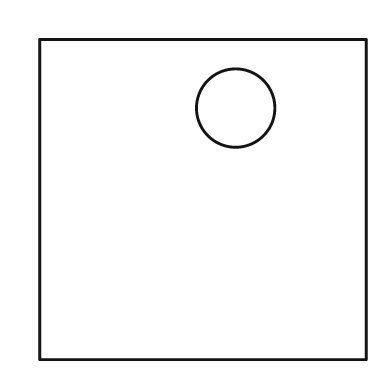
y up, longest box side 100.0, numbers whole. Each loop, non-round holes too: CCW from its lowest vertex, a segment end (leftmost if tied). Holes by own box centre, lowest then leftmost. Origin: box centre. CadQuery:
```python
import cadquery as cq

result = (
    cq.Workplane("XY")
    .moveTo(-50.0, -49.0)
    .lineTo(50.0, -49.0)
    .lineTo(50.0, 49.0)
    .lineTo(-50.0, 49.0)
    .close()
    .moveTo(10.0, 28.0)
    .circle(12.0)
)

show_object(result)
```